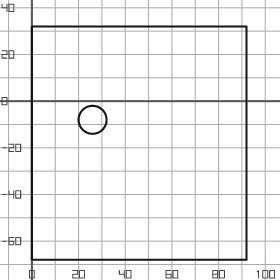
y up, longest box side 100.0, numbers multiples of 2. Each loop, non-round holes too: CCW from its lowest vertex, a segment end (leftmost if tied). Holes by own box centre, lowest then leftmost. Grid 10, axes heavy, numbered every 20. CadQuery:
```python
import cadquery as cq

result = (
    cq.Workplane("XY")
    .moveTo(0.0, -68.0)
    .lineTo(92.0, -68.0)
    .lineTo(92.0, 32.0)
    .lineTo(0.0, 32.0)
    .close()
    .moveTo(26.0, -8.0)
    .circle(6.0)
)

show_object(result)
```